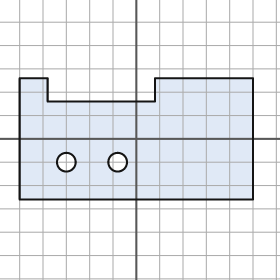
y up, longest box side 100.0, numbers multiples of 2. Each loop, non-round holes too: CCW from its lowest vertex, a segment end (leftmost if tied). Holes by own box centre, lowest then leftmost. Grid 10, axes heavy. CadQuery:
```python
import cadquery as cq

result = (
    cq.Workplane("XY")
    .moveTo(-50.0, -26.0)
    .lineTo(50.0, -26.0)
    .lineTo(50.0, 26.0)
    .lineTo(8.0, 26.0)
    .lineTo(8.0, 16.0)
    .lineTo(-38.0, 16.0)
    .lineTo(-38.0, 26.0)
    .lineTo(-50.0, 26.0)
    .close()
    .moveTo(-30.0, -10.0)
    .circle(4.0)
    .moveTo(-8.0, -10.0)
    .circle(4.0)
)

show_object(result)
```